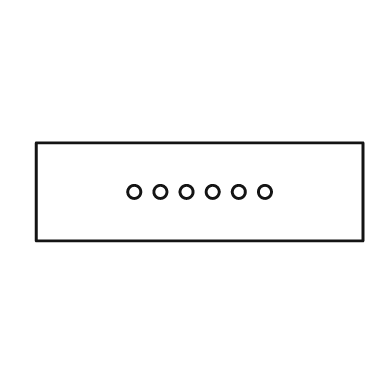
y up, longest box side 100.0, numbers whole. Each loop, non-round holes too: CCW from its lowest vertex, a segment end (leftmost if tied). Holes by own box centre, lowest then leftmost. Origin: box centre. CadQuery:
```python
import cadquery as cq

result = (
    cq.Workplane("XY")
    .moveTo(-50.0, -15.0)
    .lineTo(50.0, -15.0)
    .lineTo(50.0, 15.0)
    .lineTo(-50.0, 15.0)
    .close()
    .moveTo(-20.0, 0.0)
    .circle(2.0)
    .moveTo(-12.0, 0.0)
    .circle(2.0)
    .moveTo(-4.0, 0.0)
    .circle(2.0)
    .moveTo(4.0, 0.0)
    .circle(2.0)
    .moveTo(12.0, 0.0)
    .circle(2.0)
    .moveTo(20.0, 0.0)
    .circle(2.0)
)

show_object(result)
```